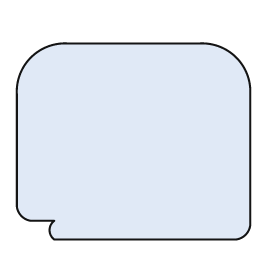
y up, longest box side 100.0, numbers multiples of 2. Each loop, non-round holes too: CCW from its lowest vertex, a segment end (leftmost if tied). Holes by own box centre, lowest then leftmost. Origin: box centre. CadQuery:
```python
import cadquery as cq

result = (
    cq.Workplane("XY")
    .moveTo(-34.0, -42.0)
    .lineTo(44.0, -42.0)
    .threePointArc((48.0, -40.0), (50.0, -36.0))
    .lineTo(50.0, 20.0)
    .threePointArc((44.0, 36.0), (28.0, 42.0))
    .lineTo(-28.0, 42.0)
    .threePointArc((-44.0, 36.0), (-50.0, 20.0))
    .lineTo(-50.0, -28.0)
    .threePointArc((-48.0, -32.0), (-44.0, -34.0))
    .lineTo(-34.0, -34.0)
    .threePointArc((-36.0, -38.0), (-34.0, -42.0))
    .close()
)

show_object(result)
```